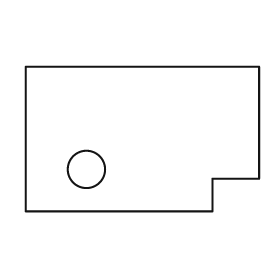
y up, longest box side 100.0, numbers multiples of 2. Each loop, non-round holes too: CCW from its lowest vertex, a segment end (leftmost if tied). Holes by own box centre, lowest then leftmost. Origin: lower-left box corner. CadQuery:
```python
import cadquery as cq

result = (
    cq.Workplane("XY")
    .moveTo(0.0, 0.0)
    .lineTo(80.0, 0.0)
    .lineTo(80.0, 14.0)
    .lineTo(100.0, 14.0)
    .lineTo(100.0, 62.0)
    .lineTo(0.0, 62.0)
    .close()
    .moveTo(26.0, 18.0)
    .circle(8.0)
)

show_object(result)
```